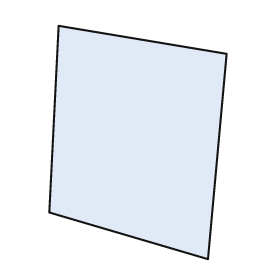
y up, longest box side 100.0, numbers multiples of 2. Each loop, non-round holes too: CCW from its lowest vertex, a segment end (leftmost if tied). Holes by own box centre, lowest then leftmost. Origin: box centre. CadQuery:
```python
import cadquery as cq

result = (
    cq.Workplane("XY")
    .moveTo(30.0, -50.0)
    .lineTo(38.0, 38.0)
    .lineTo(-34.0, 50.0)
    .lineTo(-38.0, -30.0)
    .close()
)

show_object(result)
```